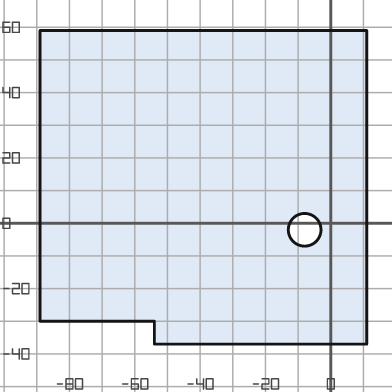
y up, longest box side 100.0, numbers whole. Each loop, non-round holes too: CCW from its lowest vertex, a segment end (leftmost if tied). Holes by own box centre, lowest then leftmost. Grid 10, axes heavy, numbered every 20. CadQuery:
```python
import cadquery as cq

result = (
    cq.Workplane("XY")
    .moveTo(-54.0, -37.0)
    .lineTo(11.0, -37.0)
    .lineTo(11.0, 59.0)
    .lineTo(-89.0, 59.0)
    .lineTo(-89.0, -30.0)
    .lineTo(-54.0, -30.0)
    .close()
    .moveTo(-8.0, -2.0)
    .circle(5.0)
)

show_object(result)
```